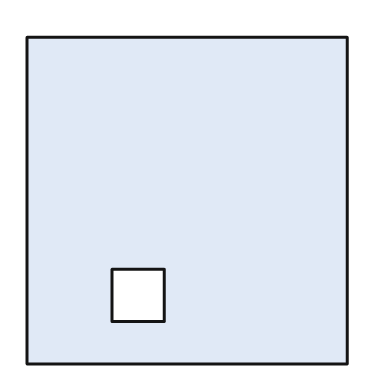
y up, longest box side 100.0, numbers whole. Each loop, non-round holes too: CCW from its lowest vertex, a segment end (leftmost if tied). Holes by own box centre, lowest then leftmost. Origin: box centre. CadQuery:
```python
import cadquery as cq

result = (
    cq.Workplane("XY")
    .moveTo(-49.0, -50.0)
    .lineTo(49.0, -50.0)
    .lineTo(49.0, 50.0)
    .lineTo(-49.0, 50.0)
    .close()
    .moveTo(-23.0, -37.0)
    .lineTo(-7.0, -37.0)
    .lineTo(-7.0, -21.0)
    .lineTo(-23.0, -21.0)
    .close()
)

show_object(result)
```